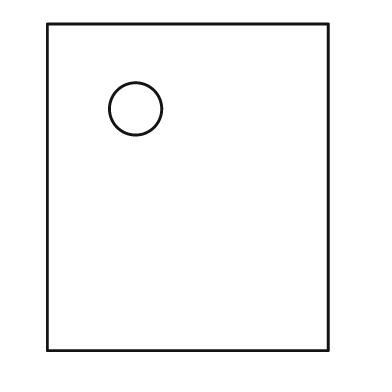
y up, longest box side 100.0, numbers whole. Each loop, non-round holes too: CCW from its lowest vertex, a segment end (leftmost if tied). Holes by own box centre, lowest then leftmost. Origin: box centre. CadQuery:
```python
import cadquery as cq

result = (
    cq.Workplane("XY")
    .moveTo(-43.0, -50.0)
    .lineTo(43.0, -50.0)
    .lineTo(43.0, 50.0)
    .lineTo(-43.0, 50.0)
    .close()
    .moveTo(-16.0, 24.0)
    .circle(8.0)
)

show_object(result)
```